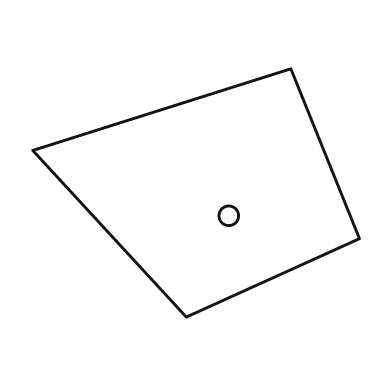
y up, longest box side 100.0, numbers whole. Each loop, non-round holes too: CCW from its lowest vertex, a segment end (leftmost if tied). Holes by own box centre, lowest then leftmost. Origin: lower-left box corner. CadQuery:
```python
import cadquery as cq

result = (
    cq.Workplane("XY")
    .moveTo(47.0, 0.0)
    .lineTo(100.0, 24.0)
    .lineTo(79.0, 76.0)
    .lineTo(0.0, 51.0)
    .close()
    .moveTo(60.0, 31.0)
    .circle(3.0)
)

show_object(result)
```